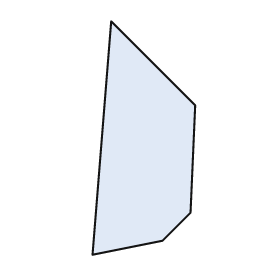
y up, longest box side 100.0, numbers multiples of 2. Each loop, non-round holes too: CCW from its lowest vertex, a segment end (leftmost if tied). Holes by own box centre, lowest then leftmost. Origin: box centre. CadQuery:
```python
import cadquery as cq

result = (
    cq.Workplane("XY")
    .moveTo(-22.0, -50.0)
    .lineTo(8.0, -44.0)
    .lineTo(20.0, -32.0)
    .lineTo(22.0, 14.0)
    .lineTo(-14.0, 50.0)
    .close()
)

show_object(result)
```